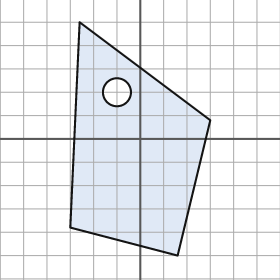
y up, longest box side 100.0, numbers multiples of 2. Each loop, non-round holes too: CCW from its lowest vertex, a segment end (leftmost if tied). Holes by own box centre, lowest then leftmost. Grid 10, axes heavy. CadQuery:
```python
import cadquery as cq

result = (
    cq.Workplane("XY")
    .moveTo(16.0, -50.0)
    .lineTo(30.0, 8.0)
    .lineTo(-26.0, 50.0)
    .lineTo(-30.0, -38.0)
    .close()
    .moveTo(-10.0, 20.0)
    .circle(6.0)
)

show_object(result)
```